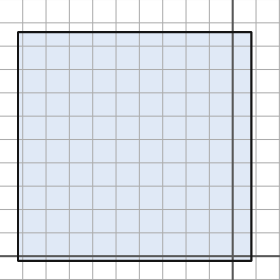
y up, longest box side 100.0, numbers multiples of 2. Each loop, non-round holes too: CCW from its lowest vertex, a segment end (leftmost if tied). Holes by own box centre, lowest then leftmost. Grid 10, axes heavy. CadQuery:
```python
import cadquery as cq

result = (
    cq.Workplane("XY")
    .moveTo(-92.0, -2.0)
    .lineTo(8.0, -2.0)
    .lineTo(8.0, 96.0)
    .lineTo(-92.0, 96.0)
    .close()
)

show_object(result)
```